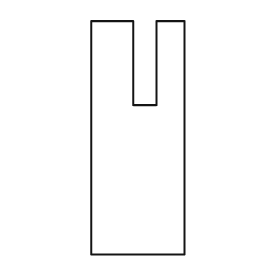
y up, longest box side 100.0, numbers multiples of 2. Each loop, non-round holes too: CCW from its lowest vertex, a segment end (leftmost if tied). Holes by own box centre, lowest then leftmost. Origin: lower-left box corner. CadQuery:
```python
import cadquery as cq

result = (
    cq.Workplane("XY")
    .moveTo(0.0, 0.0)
    .lineTo(40.0, 0.0)
    .lineTo(40.0, 100.0)
    .lineTo(28.0, 100.0)
    .lineTo(28.0, 64.0)
    .lineTo(18.0, 64.0)
    .lineTo(18.0, 100.0)
    .lineTo(0.0, 100.0)
    .close()
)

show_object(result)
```